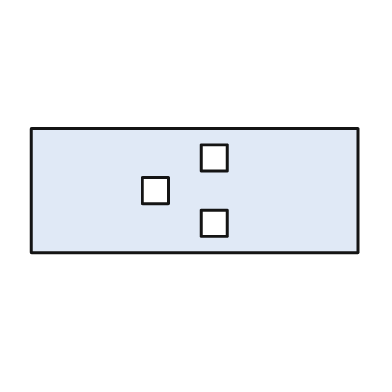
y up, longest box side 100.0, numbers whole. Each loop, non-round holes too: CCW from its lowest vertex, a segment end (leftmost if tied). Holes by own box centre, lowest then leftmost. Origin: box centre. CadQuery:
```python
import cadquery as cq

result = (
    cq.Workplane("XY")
    .moveTo(-50.0, -19.0)
    .lineTo(50.0, -19.0)
    .lineTo(50.0, 19.0)
    .lineTo(-50.0, 19.0)
    .close()
    .moveTo(2.0, -14.0)
    .lineTo(10.0, -14.0)
    .lineTo(10.0, -6.0)
    .lineTo(2.0, -6.0)
    .close()
    .moveTo(-16.0, -4.0)
    .lineTo(-8.0, -4.0)
    .lineTo(-8.0, 4.0)
    .lineTo(-16.0, 4.0)
    .close()
    .moveTo(2.0, 6.0)
    .lineTo(10.0, 6.0)
    .lineTo(10.0, 14.0)
    .lineTo(2.0, 14.0)
    .close()
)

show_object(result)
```